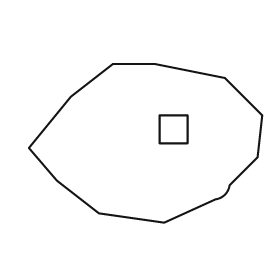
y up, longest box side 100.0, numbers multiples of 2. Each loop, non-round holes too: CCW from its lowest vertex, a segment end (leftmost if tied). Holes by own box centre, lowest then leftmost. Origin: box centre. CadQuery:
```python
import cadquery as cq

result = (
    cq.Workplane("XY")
    .moveTo(8.0, -34.0)
    .lineTo(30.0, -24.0)
    .threePointArc((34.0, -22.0), (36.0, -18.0))
    .lineTo(48.0, -6.0)
    .lineTo(50.0, 12.0)
    .lineTo(34.0, 28.0)
    .lineTo(4.0, 34.0)
    .lineTo(-14.0, 34.0)
    .lineTo(-32.0, 20.0)
    .lineTo(-50.0, -2.0)
    .lineTo(-38.0, -16.0)
    .lineTo(-20.0, -30.0)
    .close()
    .moveTo(6.0, 0.0)
    .lineTo(18.0, 0.0)
    .lineTo(18.0, 12.0)
    .lineTo(6.0, 12.0)
    .close()
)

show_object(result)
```